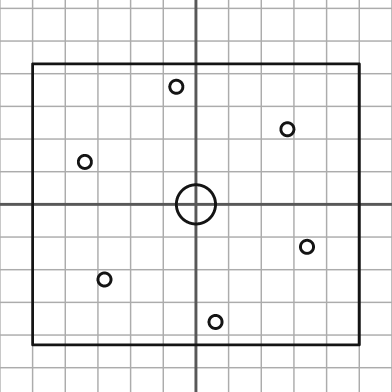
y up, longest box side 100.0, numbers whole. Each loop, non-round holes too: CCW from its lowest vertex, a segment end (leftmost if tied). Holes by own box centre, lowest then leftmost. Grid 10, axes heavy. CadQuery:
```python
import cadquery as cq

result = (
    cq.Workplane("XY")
    .moveTo(-50.0, -43.0)
    .lineTo(50.0, -43.0)
    .lineTo(50.0, 43.0)
    .lineTo(-50.0, 43.0)
    .close()
    .moveTo(6.0, -36.0)
    .circle(2.0)
    .moveTo(-28.0, -23.0)
    .circle(2.0)
    .moveTo(34.0, -13.0)
    .circle(2.0)
    .moveTo(0.0, 0.0)
    .circle(6.0)
    .moveTo(-34.0, 13.0)
    .circle(2.0)
    .moveTo(28.0, 23.0)
    .circle(2.0)
    .moveTo(-6.0, 36.0)
    .circle(2.0)
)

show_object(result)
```